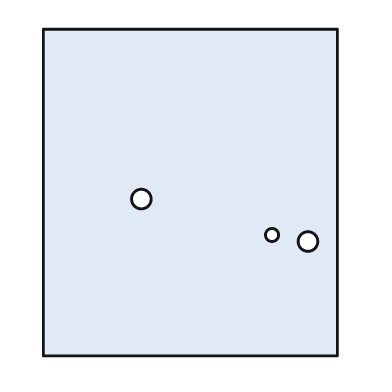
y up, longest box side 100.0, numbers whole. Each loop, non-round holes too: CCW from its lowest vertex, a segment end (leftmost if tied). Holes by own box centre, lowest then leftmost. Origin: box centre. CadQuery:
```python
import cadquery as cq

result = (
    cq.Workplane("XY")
    .moveTo(-45.0, -50.0)
    .lineTo(45.0, -50.0)
    .lineTo(45.0, 50.0)
    .lineTo(-45.0, 50.0)
    .close()
    .moveTo(36.0, -15.0)
    .circle(3.0)
    .moveTo(25.0, -13.0)
    .circle(2.0)
    .moveTo(-15.0, -2.0)
    .circle(3.0)
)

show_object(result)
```